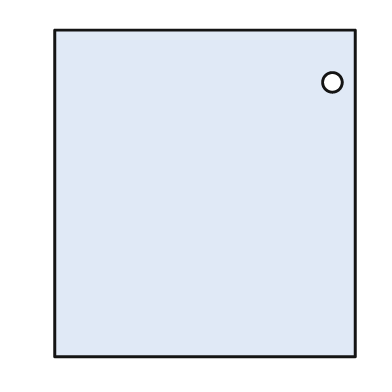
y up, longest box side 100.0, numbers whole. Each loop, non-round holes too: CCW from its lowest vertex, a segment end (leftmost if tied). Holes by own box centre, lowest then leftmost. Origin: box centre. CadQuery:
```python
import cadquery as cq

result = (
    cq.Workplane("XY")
    .moveTo(-46.0, -50.0)
    .lineTo(46.0, -50.0)
    .lineTo(46.0, 50.0)
    .lineTo(-46.0, 50.0)
    .close()
    .moveTo(39.0, 34.0)
    .circle(3.0)
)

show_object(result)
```